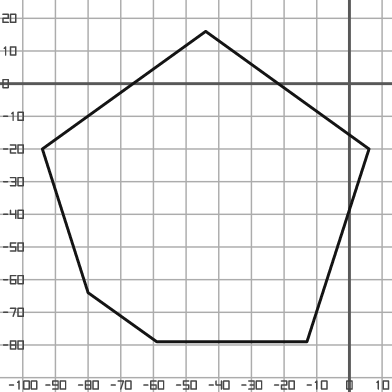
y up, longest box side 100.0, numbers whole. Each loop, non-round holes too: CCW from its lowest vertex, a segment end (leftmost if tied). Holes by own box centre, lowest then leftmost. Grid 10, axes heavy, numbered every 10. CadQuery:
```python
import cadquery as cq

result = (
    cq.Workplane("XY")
    .moveTo(-59.0, -79.0)
    .lineTo(-13.0, -79.0)
    .lineTo(6.0, -20.0)
    .lineTo(-44.0, 16.0)
    .lineTo(-94.0, -20.0)
    .lineTo(-80.0, -64.0)
    .close()
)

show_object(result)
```